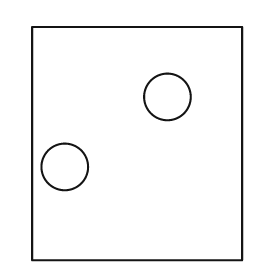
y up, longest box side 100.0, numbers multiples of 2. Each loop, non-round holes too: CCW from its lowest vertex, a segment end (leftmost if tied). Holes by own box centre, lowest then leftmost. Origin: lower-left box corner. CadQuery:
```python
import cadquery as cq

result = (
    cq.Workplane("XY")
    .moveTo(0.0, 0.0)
    .lineTo(90.0, 0.0)
    .lineTo(90.0, 100.0)
    .lineTo(0.0, 100.0)
    .close()
    .moveTo(14.0, 40.0)
    .circle(10.0)
    .moveTo(58.0, 70.0)
    .circle(10.0)
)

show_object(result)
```